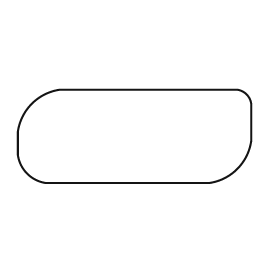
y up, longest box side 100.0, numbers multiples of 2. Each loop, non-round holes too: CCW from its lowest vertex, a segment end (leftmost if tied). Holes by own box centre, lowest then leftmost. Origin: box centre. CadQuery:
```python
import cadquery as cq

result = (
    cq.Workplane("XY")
    .moveTo(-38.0, -20.0)
    .lineTo(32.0, -20.0)
    .threePointArc((44.0, -14.0), (50.0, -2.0))
    .lineTo(50.0, 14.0)
    .threePointArc((48.0, 18.0), (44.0, 20.0))
    .lineTo(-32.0, 20.0)
    .threePointArc((-44.0, 14.0), (-50.0, 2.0))
    .lineTo(-50.0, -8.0)
    .threePointArc((-46.0, -16.0), (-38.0, -20.0))
    .close()
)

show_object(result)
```